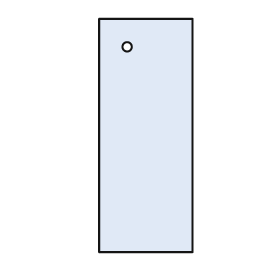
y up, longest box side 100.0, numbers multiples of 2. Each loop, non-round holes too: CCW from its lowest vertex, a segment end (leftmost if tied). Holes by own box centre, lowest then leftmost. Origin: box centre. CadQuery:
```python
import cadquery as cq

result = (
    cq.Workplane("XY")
    .moveTo(-20.0, -50.0)
    .lineTo(20.0, -50.0)
    .lineTo(20.0, 50.0)
    .lineTo(-20.0, 50.0)
    .close()
    .moveTo(-8.0, 38.0)
    .circle(2.0)
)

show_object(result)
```